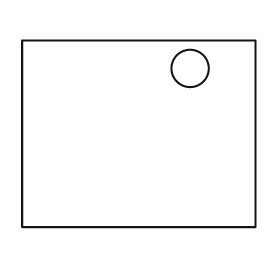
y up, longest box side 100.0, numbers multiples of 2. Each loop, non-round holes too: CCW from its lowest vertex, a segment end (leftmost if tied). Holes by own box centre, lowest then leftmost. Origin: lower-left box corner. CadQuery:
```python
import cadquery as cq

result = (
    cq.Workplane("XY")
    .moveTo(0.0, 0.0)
    .lineTo(100.0, 0.0)
    .lineTo(100.0, 80.0)
    .lineTo(0.0, 80.0)
    .close()
    .moveTo(72.0, 68.0)
    .circle(8.0)
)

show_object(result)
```